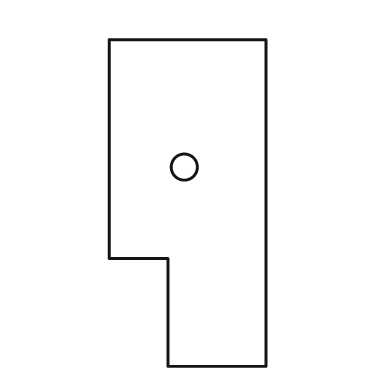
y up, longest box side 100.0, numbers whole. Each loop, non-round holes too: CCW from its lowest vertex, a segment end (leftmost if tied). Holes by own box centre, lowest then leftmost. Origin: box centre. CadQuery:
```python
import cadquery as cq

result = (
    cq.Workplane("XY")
    .moveTo(-6.0, -50.0)
    .lineTo(24.0, -50.0)
    .lineTo(24.0, 50.0)
    .lineTo(-24.0, 50.0)
    .lineTo(-24.0, -17.0)
    .lineTo(-6.0, -17.0)
    .close()
    .moveTo(-1.0, 11.0)
    .circle(4.0)
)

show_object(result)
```